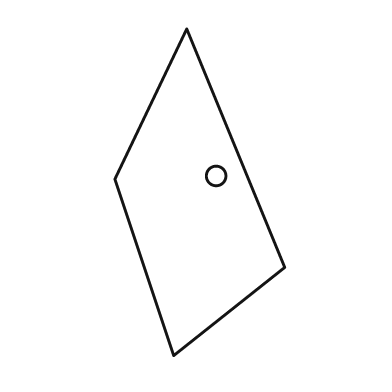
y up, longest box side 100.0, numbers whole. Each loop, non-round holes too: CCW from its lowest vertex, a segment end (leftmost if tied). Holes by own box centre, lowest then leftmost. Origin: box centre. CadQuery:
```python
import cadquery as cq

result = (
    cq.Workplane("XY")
    .moveTo(-8.0, -50.0)
    .lineTo(26.0, -23.0)
    .lineTo(-4.0, 50.0)
    .lineTo(-26.0, 4.0)
    .close()
    .moveTo(5.0, 5.0)
    .circle(3.0)
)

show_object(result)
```